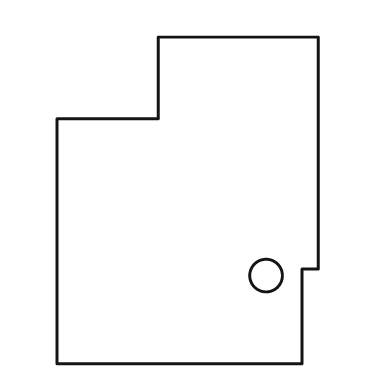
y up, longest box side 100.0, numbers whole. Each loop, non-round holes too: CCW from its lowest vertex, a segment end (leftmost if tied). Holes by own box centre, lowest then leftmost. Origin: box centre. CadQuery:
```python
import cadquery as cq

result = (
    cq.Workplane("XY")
    .moveTo(-40.0, -50.0)
    .lineTo(35.0, -50.0)
    .lineTo(35.0, -21.0)
    .lineTo(40.0, -21.0)
    .lineTo(40.0, 50.0)
    .lineTo(-9.0, 50.0)
    .lineTo(-9.0, 25.0)
    .lineTo(-40.0, 25.0)
    .close()
    .moveTo(24.0, -23.0)
    .circle(5.0)
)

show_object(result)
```